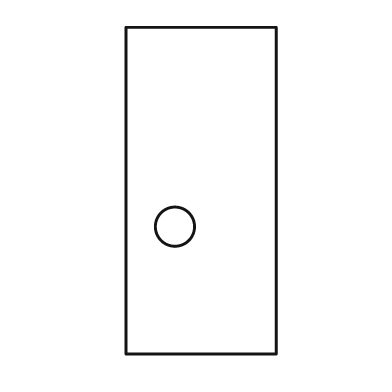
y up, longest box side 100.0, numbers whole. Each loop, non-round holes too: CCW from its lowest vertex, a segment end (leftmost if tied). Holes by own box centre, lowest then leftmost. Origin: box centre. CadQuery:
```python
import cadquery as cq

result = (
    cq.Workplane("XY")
    .moveTo(-23.0, -50.0)
    .lineTo(23.0, -50.0)
    .lineTo(23.0, 50.0)
    .lineTo(-23.0, 50.0)
    .close()
    .moveTo(-8.0, -11.0)
    .circle(6.0)
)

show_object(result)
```